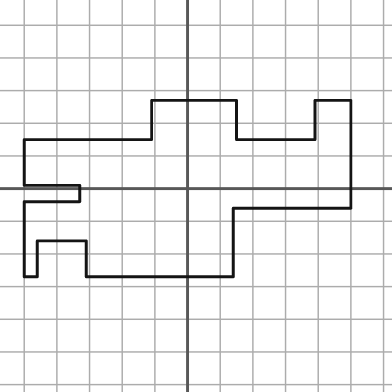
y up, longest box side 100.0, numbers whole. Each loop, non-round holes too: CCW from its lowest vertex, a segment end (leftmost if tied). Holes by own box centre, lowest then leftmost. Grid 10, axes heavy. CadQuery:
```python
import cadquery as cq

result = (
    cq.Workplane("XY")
    .moveTo(-50.0, -27.0)
    .lineTo(-46.0, -27.0)
    .lineTo(-46.0, -16.0)
    .lineTo(-31.0, -16.0)
    .lineTo(-31.0, -27.0)
    .lineTo(14.0, -27.0)
    .lineTo(14.0, -6.0)
    .lineTo(50.0, -6.0)
    .lineTo(50.0, 27.0)
    .lineTo(39.0, 27.0)
    .lineTo(39.0, 15.0)
    .lineTo(15.0, 15.0)
    .lineTo(15.0, 27.0)
    .lineTo(-11.0, 27.0)
    .lineTo(-11.0, 15.0)
    .lineTo(-50.0, 15.0)
    .lineTo(-50.0, 1.0)
    .lineTo(-33.0, 1.0)
    .lineTo(-33.0, -4.0)
    .lineTo(-50.0, -4.0)
    .close()
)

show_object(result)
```